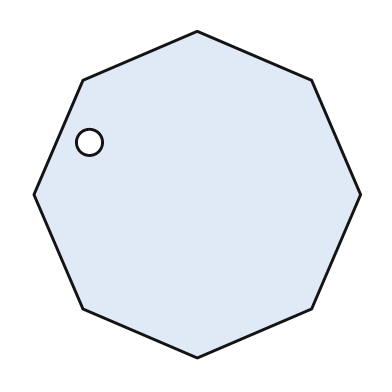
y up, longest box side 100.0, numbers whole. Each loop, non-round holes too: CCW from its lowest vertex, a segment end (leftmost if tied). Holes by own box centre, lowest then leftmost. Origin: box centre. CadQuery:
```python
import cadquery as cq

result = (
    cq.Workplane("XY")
    .moveTo(0.0, -50.0)
    .lineTo(35.0, -35.0)
    .lineTo(50.0, 0.0)
    .lineTo(35.0, 35.0)
    .lineTo(0.0, 50.0)
    .lineTo(-35.0, 35.0)
    .lineTo(-50.0, 0.0)
    .lineTo(-35.0, -35.0)
    .close()
    .moveTo(-33.0, 16.0)
    .circle(4.0)
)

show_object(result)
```